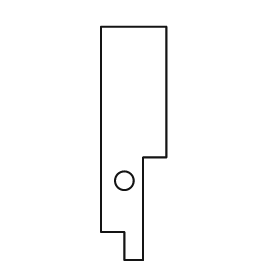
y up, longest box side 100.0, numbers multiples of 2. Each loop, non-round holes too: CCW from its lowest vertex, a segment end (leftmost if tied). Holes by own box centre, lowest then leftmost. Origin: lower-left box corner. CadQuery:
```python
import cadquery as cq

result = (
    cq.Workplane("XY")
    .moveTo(10.0, 0.0)
    .lineTo(18.0, 0.0)
    .lineTo(18.0, 44.0)
    .lineTo(28.0, 44.0)
    .lineTo(28.0, 100.0)
    .lineTo(0.0, 100.0)
    .lineTo(0.0, 12.0)
    .lineTo(10.0, 12.0)
    .close()
    .moveTo(10.0, 34.0)
    .circle(4.0)
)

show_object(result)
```